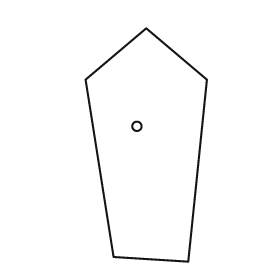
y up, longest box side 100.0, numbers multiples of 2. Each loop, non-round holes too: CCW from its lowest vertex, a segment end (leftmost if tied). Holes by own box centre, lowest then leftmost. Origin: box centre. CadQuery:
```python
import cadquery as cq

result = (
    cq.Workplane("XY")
    .moveTo(18.0, -50.0)
    .lineTo(26.0, 28.0)
    .lineTo(0.0, 50.0)
    .lineTo(-26.0, 28.0)
    .lineTo(-14.0, -48.0)
    .close()
    .moveTo(-4.0, 8.0)
    .circle(2.0)
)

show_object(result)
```